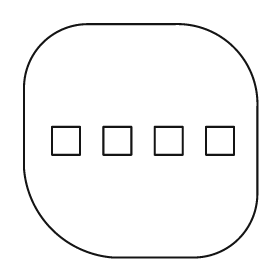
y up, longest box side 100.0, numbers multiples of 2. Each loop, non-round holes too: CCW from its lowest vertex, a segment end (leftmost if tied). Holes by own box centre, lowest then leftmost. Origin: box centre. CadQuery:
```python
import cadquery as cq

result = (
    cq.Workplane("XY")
    .moveTo(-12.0, -50.0)
    .lineTo(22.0, -50.0)
    .threePointArc((42.0, -42.0), (50.0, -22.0))
    .lineTo(50.0, 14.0)
    .threePointArc((40.0, 40.0), (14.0, 50.0))
    .lineTo(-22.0, 50.0)
    .threePointArc((-42.0, 42.0), (-50.0, 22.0))
    .lineTo(-50.0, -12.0)
    .threePointArc((-38.0, -38.0), (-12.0, -50.0))
    .close()
    .moveTo(-38.0, -6.0)
    .lineTo(-26.0, -6.0)
    .lineTo(-26.0, 6.0)
    .lineTo(-38.0, 6.0)
    .close()
    .moveTo(-16.0, -6.0)
    .lineTo(-4.0, -6.0)
    .lineTo(-4.0, 6.0)
    .lineTo(-16.0, 6.0)
    .close()
    .moveTo(6.0, -6.0)
    .lineTo(18.0, -6.0)
    .lineTo(18.0, 6.0)
    .lineTo(6.0, 6.0)
    .close()
    .moveTo(28.0, -6.0)
    .lineTo(40.0, -6.0)
    .lineTo(40.0, 6.0)
    .lineTo(28.0, 6.0)
    .close()
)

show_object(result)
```